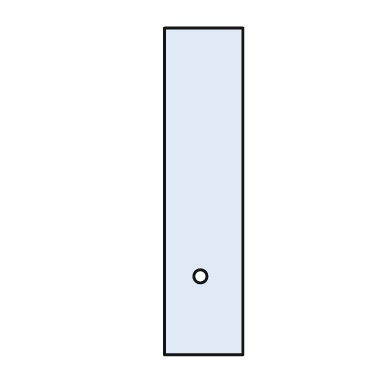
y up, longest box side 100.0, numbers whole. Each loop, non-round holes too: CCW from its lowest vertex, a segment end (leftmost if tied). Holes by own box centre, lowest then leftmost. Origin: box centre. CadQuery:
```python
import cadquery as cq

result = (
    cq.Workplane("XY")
    .moveTo(-12.0, -50.0)
    .lineTo(12.0, -50.0)
    .lineTo(12.0, 50.0)
    .lineTo(-12.0, 50.0)
    .close()
    .moveTo(-1.0, -26.0)
    .circle(2.0)
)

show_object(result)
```